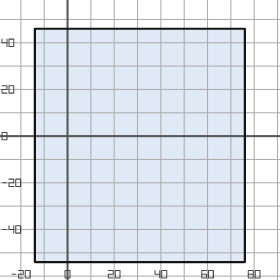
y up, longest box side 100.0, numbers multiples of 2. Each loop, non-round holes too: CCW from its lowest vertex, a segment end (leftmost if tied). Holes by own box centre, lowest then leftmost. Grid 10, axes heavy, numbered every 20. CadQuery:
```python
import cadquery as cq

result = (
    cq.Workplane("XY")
    .moveTo(-14.0, -54.0)
    .lineTo(76.0, -54.0)
    .lineTo(76.0, 46.0)
    .lineTo(-14.0, 46.0)
    .close()
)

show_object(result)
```